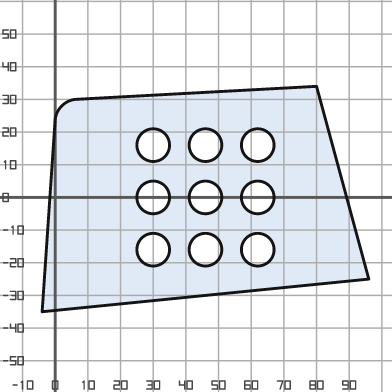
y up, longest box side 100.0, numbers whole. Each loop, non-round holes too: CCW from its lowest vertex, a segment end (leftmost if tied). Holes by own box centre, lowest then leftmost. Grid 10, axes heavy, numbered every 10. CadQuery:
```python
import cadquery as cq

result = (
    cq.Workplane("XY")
    .moveTo(-4.0, -35.0)
    .lineTo(96.0, -25.0)
    .lineTo(80.0, 34.0)
    .lineTo(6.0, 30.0)
    .threePointArc((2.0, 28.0), (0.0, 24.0))
    .close()
    .moveTo(30.0, -16.0)
    .circle(5.0)
    .moveTo(46.0, -16.0)
    .circle(5.0)
    .moveTo(62.0, -16.0)
    .circle(5.0)
    .moveTo(30.0, 0.0)
    .circle(5.0)
    .moveTo(46.0, 0.0)
    .circle(5.0)
    .moveTo(62.0, 0.0)
    .circle(5.0)
    .moveTo(30.0, 16.0)
    .circle(5.0)
    .moveTo(46.0, 16.0)
    .circle(5.0)
    .moveTo(62.0, 16.0)
    .circle(5.0)
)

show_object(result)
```